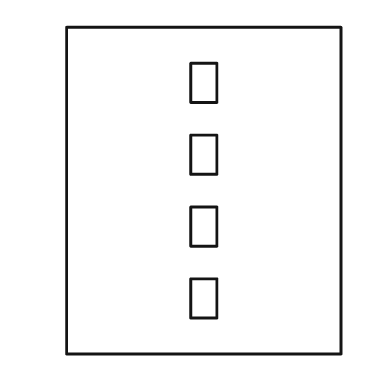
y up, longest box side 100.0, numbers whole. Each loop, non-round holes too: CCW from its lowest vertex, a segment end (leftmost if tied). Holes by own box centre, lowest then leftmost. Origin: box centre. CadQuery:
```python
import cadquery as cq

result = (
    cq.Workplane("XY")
    .moveTo(-42.0, -50.0)
    .lineTo(42.0, -50.0)
    .lineTo(42.0, 50.0)
    .lineTo(-42.0, 50.0)
    .close()
    .moveTo(-4.0, -39.0)
    .lineTo(4.0, -39.0)
    .lineTo(4.0, -27.0)
    .lineTo(-4.0, -27.0)
    .close()
    .moveTo(-4.0, -17.0)
    .lineTo(4.0, -17.0)
    .lineTo(4.0, -5.0)
    .lineTo(-4.0, -5.0)
    .close()
    .moveTo(-4.0, 5.0)
    .lineTo(4.0, 5.0)
    .lineTo(4.0, 17.0)
    .lineTo(-4.0, 17.0)
    .close()
    .moveTo(-4.0, 27.0)
    .lineTo(4.0, 27.0)
    .lineTo(4.0, 39.0)
    .lineTo(-4.0, 39.0)
    .close()
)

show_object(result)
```